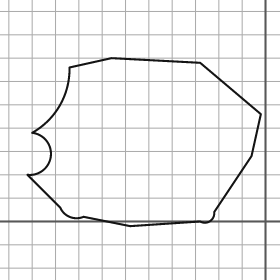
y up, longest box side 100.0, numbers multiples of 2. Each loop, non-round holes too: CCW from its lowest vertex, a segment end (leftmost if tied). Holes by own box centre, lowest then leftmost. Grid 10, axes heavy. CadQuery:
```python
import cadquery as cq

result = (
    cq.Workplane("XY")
    .moveTo(-58.0, -2.0)
    .lineTo(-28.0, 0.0)
    .threePointArc((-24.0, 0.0), (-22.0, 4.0))
    .lineTo(-6.0, 28.0)
    .lineTo(-2.0, 46.0)
    .lineTo(-28.0, 68.0)
    .lineTo(-66.0, 70.0)
    .lineTo(-84.0, 66.0)
    .threePointArc((-88.0, 50.0), (-100.0, 38.0))
    .threePointArc((-92.0, 28.0), (-102.0, 20.0))
    .lineTo(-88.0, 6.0)
    .threePointArc((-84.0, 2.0), (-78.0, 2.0))
    .close()
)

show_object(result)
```